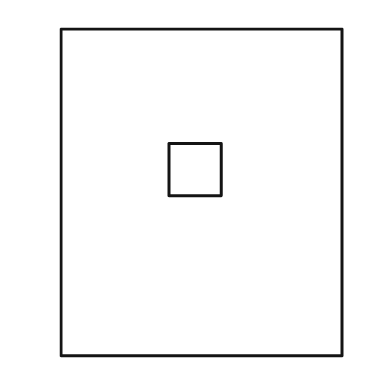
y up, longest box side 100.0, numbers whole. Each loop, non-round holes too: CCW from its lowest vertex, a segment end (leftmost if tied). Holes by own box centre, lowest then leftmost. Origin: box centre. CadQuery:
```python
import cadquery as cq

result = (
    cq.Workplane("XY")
    .moveTo(-43.0, -50.0)
    .lineTo(43.0, -50.0)
    .lineTo(43.0, 50.0)
    .lineTo(-43.0, 50.0)
    .close()
    .moveTo(-10.0, -1.0)
    .lineTo(6.0, -1.0)
    .lineTo(6.0, 15.0)
    .lineTo(-10.0, 15.0)
    .close()
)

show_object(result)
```